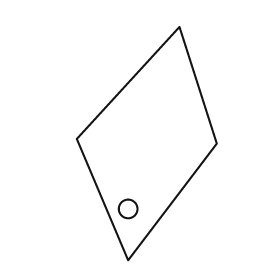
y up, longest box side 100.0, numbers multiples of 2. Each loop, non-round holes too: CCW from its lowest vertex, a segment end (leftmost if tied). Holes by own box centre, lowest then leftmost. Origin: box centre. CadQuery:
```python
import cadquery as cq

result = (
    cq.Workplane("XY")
    .moveTo(-8.0, -50.0)
    .lineTo(30.0, 0.0)
    .lineTo(14.0, 50.0)
    .lineTo(-30.0, 2.0)
    .close()
    .moveTo(-8.0, -28.0)
    .circle(4.0)
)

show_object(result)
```